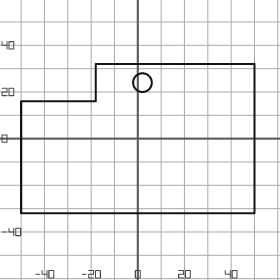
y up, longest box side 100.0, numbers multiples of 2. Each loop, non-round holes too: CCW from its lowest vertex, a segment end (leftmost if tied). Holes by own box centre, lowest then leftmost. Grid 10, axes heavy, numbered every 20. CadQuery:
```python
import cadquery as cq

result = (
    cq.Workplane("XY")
    .moveTo(-50.0, -32.0)
    .lineTo(50.0, -32.0)
    .lineTo(50.0, 32.0)
    .lineTo(-18.0, 32.0)
    .lineTo(-18.0, 16.0)
    .lineTo(-50.0, 16.0)
    .close()
    .moveTo(2.0, 24.0)
    .circle(4.0)
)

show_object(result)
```